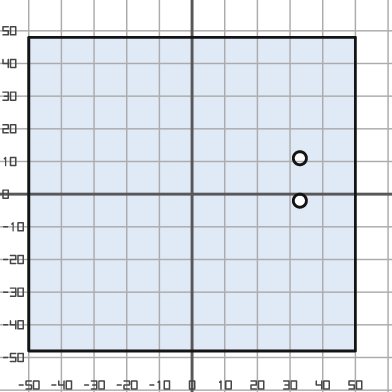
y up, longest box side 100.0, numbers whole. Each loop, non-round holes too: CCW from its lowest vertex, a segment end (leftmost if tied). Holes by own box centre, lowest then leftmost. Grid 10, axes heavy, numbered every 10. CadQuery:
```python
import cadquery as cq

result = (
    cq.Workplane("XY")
    .moveTo(-50.0, -48.0)
    .lineTo(50.0, -48.0)
    .lineTo(50.0, 48.0)
    .lineTo(-50.0, 48.0)
    .close()
    .moveTo(33.0, -2.0)
    .circle(2.0)
    .moveTo(33.0, 11.0)
    .circle(2.0)
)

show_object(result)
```